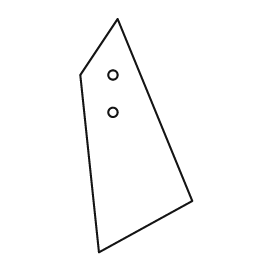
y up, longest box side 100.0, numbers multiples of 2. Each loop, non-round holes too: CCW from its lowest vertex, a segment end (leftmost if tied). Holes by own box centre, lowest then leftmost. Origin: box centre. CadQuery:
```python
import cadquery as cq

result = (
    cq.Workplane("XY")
    .moveTo(-16.0, -50.0)
    .lineTo(24.0, -28.0)
    .lineTo(-8.0, 50.0)
    .lineTo(-24.0, 26.0)
    .close()
    .moveTo(-10.0, 10.0)
    .circle(2.0)
    .moveTo(-10.0, 26.0)
    .circle(2.0)
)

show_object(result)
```